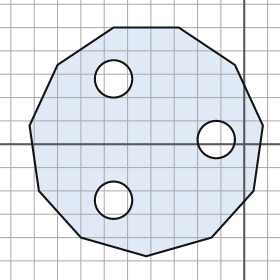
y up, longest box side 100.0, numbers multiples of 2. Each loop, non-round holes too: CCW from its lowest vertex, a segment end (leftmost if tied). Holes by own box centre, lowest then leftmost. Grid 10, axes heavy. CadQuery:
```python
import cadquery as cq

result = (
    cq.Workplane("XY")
    .moveTo(-42.0, -48.0)
    .lineTo(-14.0, -40.0)
    .lineTo(4.0, -20.0)
    .lineTo(8.0, 8.0)
    .lineTo(-4.0, 34.0)
    .lineTo(-28.0, 50.0)
    .lineTo(-56.0, 50.0)
    .lineTo(-80.0, 34.0)
    .lineTo(-92.0, 8.0)
    .lineTo(-88.0, -20.0)
    .lineTo(-70.0, -40.0)
    .close()
    .moveTo(-56.0, -24.0)
    .circle(8.0)
    .moveTo(-12.0, 2.0)
    .circle(8.0)
    .moveTo(-56.0, 28.0)
    .circle(8.0)
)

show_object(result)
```